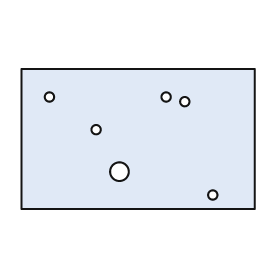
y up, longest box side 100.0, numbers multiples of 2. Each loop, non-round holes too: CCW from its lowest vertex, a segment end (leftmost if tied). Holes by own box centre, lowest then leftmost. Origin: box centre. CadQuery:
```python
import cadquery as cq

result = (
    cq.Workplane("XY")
    .moveTo(-50.0, -30.0)
    .lineTo(50.0, -30.0)
    .lineTo(50.0, 30.0)
    .lineTo(-50.0, 30.0)
    .close()
    .moveTo(32.0, -24.0)
    .circle(2.0)
    .moveTo(-8.0, -14.0)
    .circle(4.0)
    .moveTo(-18.0, 4.0)
    .circle(2.0)
    .moveTo(20.0, 16.0)
    .circle(2.0)
    .moveTo(-38.0, 18.0)
    .circle(2.0)
    .moveTo(12.0, 18.0)
    .circle(2.0)
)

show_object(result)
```